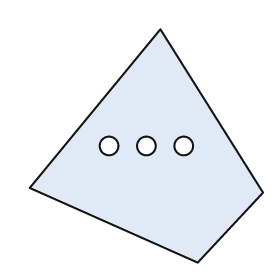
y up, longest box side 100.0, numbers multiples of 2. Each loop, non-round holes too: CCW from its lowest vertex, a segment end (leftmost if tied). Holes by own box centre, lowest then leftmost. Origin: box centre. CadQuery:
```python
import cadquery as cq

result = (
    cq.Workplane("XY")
    .moveTo(22.0, -50.0)
    .lineTo(50.0, -20.0)
    .lineTo(6.0, 50.0)
    .lineTo(-50.0, -18.0)
    .close()
    .moveTo(-16.0, 0.0)
    .circle(4.0)
    .moveTo(0.0, 0.0)
    .circle(4.0)
    .moveTo(16.0, 0.0)
    .circle(4.0)
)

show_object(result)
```